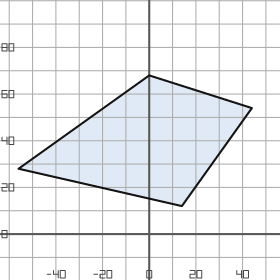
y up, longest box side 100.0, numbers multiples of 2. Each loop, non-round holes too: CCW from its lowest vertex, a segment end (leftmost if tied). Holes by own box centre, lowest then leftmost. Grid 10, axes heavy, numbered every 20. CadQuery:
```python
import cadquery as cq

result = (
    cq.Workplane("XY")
    .moveTo(14.0, 12.0)
    .lineTo(44.0, 54.0)
    .lineTo(0.0, 68.0)
    .lineTo(-56.0, 28.0)
    .close()
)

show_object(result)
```